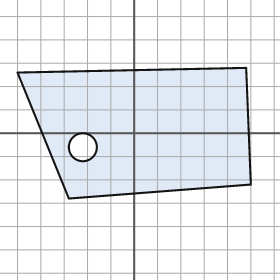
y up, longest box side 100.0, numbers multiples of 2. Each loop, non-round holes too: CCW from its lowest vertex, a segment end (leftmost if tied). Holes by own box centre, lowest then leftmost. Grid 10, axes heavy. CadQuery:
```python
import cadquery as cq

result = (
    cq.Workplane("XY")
    .moveTo(-28.0, -28.0)
    .lineTo(50.0, -22.0)
    .lineTo(48.0, 28.0)
    .lineTo(-50.0, 26.0)
    .close()
    .moveTo(-22.0, -6.0)
    .circle(6.0)
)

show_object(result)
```